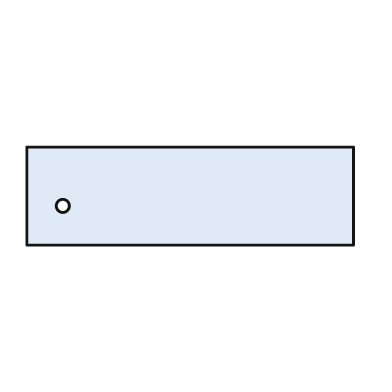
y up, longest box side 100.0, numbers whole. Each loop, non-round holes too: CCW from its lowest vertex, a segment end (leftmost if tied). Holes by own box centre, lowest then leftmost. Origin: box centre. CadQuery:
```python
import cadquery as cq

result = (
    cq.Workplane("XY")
    .moveTo(-50.0, -15.0)
    .lineTo(50.0, -15.0)
    .lineTo(50.0, 15.0)
    .lineTo(-50.0, 15.0)
    .close()
    .moveTo(-39.0, -3.0)
    .circle(2.0)
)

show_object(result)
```